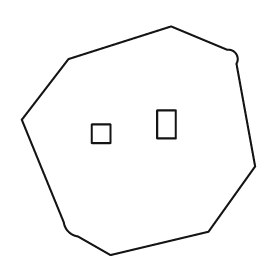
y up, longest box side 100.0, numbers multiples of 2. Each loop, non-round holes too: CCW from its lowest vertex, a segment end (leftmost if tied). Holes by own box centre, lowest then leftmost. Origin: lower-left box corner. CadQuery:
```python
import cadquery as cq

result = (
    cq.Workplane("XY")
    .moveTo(38.0, 0.0)
    .lineTo(80.0, 10.0)
    .lineTo(100.0, 38.0)
    .lineTo(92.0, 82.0)
    .threePointArc((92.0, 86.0), (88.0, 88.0))
    .lineTo(64.0, 98.0)
    .lineTo(20.0, 84.0)
    .lineTo(0.0, 58.0)
    .lineTo(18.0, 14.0)
    .threePointArc((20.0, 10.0), (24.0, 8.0))
    .close()
    .moveTo(30.0, 48.0)
    .lineTo(38.0, 48.0)
    .lineTo(38.0, 56.0)
    .lineTo(30.0, 56.0)
    .close()
    .moveTo(58.0, 50.0)
    .lineTo(66.0, 50.0)
    .lineTo(66.0, 62.0)
    .lineTo(58.0, 62.0)
    .close()
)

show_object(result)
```